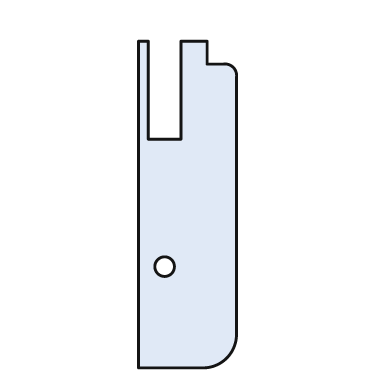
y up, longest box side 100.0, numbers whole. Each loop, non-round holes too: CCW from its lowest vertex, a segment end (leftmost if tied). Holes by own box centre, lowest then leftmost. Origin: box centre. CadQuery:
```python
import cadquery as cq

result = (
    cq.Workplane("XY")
    .moveTo(-15.0, -50.0)
    .lineTo(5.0, -50.0)
    .threePointArc((12.0, -47.0), (15.0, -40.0))
    .lineTo(15.0, 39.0)
    .threePointArc((14.0, 42.0), (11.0, 43.0))
    .lineTo(6.0, 43.0)
    .lineTo(6.0, 50.0)
    .lineTo(-2.0, 50.0)
    .lineTo(-2.0, 20.0)
    .lineTo(-12.0, 20.0)
    .lineTo(-12.0, 50.0)
    .lineTo(-15.0, 50.0)
    .close()
    .moveTo(-7.0, -19.0)
    .circle(3.0)
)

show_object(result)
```